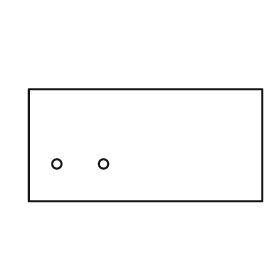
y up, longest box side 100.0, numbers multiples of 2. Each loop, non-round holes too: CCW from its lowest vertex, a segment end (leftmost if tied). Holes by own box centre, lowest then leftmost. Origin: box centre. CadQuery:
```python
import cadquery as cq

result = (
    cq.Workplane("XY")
    .moveTo(-50.0, -24.0)
    .lineTo(50.0, -24.0)
    .lineTo(50.0, 24.0)
    .lineTo(-50.0, 24.0)
    .close()
    .moveTo(-38.0, -8.0)
    .circle(2.0)
    .moveTo(-18.0, -8.0)
    .circle(2.0)
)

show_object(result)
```